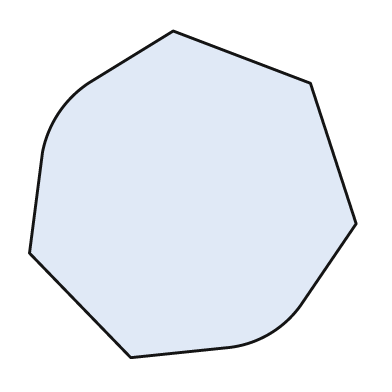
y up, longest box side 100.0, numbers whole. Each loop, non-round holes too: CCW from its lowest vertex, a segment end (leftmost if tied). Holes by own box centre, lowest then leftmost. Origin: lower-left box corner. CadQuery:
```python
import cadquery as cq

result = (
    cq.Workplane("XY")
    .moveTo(31.0, 0.0)
    .lineTo(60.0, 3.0)
    .threePointArc((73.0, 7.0), (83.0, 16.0))
    .lineTo(100.0, 41.0)
    .lineTo(86.0, 84.0)
    .lineTo(44.0, 100.0)
    .lineTo(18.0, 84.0)
    .threePointArc((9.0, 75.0), (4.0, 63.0))
    .lineTo(0.0, 32.0)
    .close()
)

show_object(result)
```